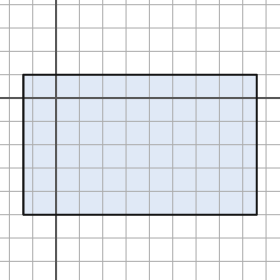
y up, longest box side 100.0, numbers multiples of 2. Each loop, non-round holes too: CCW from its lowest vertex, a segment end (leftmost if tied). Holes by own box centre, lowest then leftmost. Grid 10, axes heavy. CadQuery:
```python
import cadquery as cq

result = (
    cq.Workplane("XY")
    .moveTo(-14.0, -50.0)
    .lineTo(86.0, -50.0)
    .lineTo(86.0, 10.0)
    .lineTo(-14.0, 10.0)
    .close()
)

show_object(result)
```